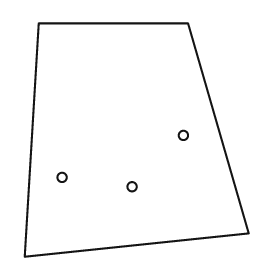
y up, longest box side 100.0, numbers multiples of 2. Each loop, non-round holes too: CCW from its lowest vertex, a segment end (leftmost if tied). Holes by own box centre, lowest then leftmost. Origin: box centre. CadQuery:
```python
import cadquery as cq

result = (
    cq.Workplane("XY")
    .moveTo(-48.0, -50.0)
    .lineTo(48.0, -40.0)
    .lineTo(22.0, 50.0)
    .lineTo(-42.0, 50.0)
    .close()
    .moveTo(-2.0, -20.0)
    .circle(2.0)
    .moveTo(-32.0, -16.0)
    .circle(2.0)
    .moveTo(20.0, 2.0)
    .circle(2.0)
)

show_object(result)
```